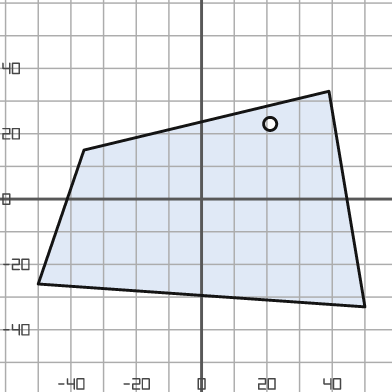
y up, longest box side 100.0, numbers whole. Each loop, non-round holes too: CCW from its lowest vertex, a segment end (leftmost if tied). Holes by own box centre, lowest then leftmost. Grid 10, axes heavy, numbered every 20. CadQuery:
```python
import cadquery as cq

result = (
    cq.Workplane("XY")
    .moveTo(50.0, -33.0)
    .lineTo(39.0, 33.0)
    .lineTo(-36.0, 15.0)
    .lineTo(-50.0, -26.0)
    .close()
    .moveTo(21.0, 23.0)
    .circle(2.0)
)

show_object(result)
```